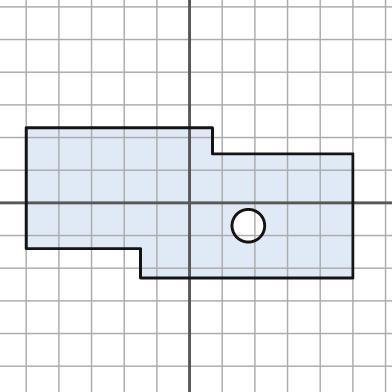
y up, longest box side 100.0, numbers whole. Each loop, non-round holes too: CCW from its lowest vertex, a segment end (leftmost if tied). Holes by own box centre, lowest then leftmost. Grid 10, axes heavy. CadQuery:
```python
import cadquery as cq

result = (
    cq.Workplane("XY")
    .moveTo(-15.0, -23.0)
    .lineTo(50.0, -23.0)
    .lineTo(50.0, 15.0)
    .lineTo(7.0, 15.0)
    .lineTo(7.0, 23.0)
    .lineTo(-50.0, 23.0)
    .lineTo(-50.0, -14.0)
    .lineTo(-15.0, -14.0)
    .close()
    .moveTo(18.0, -7.0)
    .circle(5.0)
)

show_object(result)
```